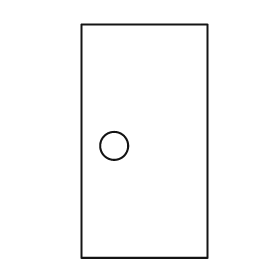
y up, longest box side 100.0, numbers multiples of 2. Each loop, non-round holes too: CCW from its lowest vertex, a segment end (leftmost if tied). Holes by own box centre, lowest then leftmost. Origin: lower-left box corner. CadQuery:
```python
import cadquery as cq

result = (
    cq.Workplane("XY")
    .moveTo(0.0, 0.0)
    .lineTo(54.0, 0.0)
    .lineTo(54.0, 100.0)
    .lineTo(0.0, 100.0)
    .close()
    .moveTo(14.0, 48.0)
    .circle(6.0)
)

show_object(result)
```